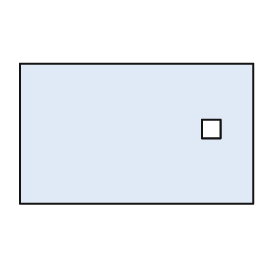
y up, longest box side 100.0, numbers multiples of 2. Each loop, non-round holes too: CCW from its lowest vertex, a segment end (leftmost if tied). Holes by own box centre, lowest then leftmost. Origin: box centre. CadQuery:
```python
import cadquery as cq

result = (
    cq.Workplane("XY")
    .moveTo(-50.0, -30.0)
    .lineTo(50.0, -30.0)
    .lineTo(50.0, 30.0)
    .lineTo(-50.0, 30.0)
    .close()
    .moveTo(28.0, -2.0)
    .lineTo(36.0, -2.0)
    .lineTo(36.0, 6.0)
    .lineTo(28.0, 6.0)
    .close()
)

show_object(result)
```